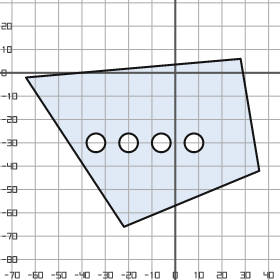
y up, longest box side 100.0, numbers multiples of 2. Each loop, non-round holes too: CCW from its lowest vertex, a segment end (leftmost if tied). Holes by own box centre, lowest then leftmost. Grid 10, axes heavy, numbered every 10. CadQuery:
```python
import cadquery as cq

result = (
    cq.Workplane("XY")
    .moveTo(-22.0, -66.0)
    .lineTo(36.0, -42.0)
    .lineTo(28.0, 6.0)
    .lineTo(-64.0, -2.0)
    .close()
    .moveTo(-34.0, -30.0)
    .circle(4.0)
    .moveTo(-20.0, -30.0)
    .circle(4.0)
    .moveTo(-6.0, -30.0)
    .circle(4.0)
    .moveTo(8.0, -30.0)
    .circle(4.0)
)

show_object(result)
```